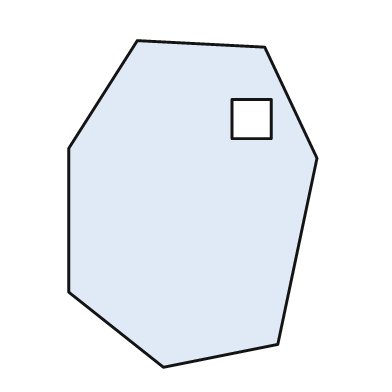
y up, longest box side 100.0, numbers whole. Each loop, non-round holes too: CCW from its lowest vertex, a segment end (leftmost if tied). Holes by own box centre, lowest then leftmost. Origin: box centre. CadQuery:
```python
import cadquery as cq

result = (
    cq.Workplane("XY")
    .moveTo(-9.0, -50.0)
    .lineTo(26.0, -43.0)
    .lineTo(38.0, 14.0)
    .lineTo(22.0, 48.0)
    .lineTo(-17.0, 50.0)
    .lineTo(-38.0, 17.0)
    .lineTo(-38.0, -27.0)
    .close()
    .moveTo(12.0, 20.0)
    .lineTo(24.0, 20.0)
    .lineTo(24.0, 32.0)
    .lineTo(12.0, 32.0)
    .close()
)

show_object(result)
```